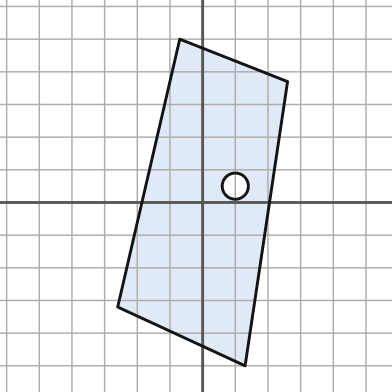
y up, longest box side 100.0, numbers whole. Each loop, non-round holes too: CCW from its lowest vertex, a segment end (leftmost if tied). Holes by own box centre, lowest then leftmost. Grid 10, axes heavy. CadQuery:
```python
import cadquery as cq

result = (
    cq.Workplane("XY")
    .moveTo(13.0, -50.0)
    .lineTo(26.0, 37.0)
    .lineTo(-7.0, 50.0)
    .lineTo(-26.0, -32.0)
    .close()
    .moveTo(10.0, 5.0)
    .circle(4.0)
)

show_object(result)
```